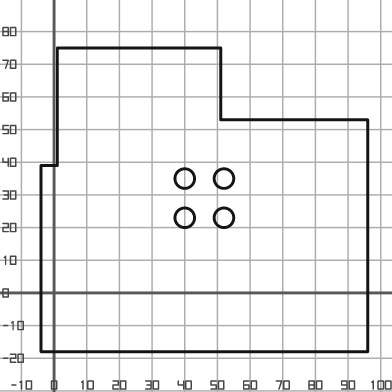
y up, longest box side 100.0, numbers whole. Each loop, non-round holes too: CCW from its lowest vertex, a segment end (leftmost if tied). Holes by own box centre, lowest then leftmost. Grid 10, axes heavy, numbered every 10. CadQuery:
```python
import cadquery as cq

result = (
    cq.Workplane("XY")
    .moveTo(-4.0, -18.0)
    .lineTo(96.0, -18.0)
    .lineTo(96.0, 53.0)
    .lineTo(51.0, 53.0)
    .lineTo(51.0, 75.0)
    .lineTo(1.0, 75.0)
    .lineTo(1.0, 39.0)
    .lineTo(-4.0, 39.0)
    .close()
    .moveTo(40.0, 23.0)
    .circle(3.0)
    .moveTo(52.0, 23.0)
    .circle(3.0)
    .moveTo(40.0, 35.0)
    .circle(3.0)
    .moveTo(52.0, 35.0)
    .circle(3.0)
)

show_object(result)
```